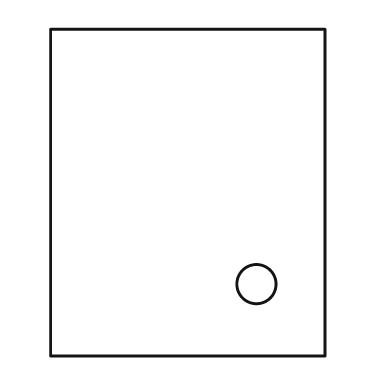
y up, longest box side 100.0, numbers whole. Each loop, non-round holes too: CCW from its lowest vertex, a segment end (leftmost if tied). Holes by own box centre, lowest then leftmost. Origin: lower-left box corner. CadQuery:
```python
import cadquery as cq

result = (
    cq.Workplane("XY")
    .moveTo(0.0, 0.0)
    .lineTo(84.0, 0.0)
    .lineTo(84.0, 100.0)
    .lineTo(0.0, 100.0)
    .close()
    .moveTo(63.0, 22.0)
    .circle(6.0)
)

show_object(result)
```